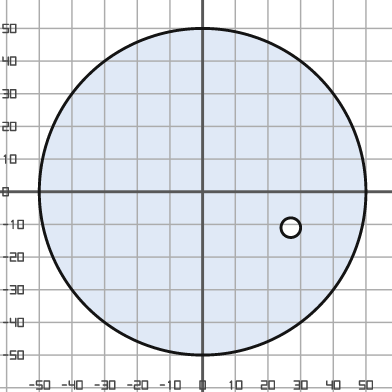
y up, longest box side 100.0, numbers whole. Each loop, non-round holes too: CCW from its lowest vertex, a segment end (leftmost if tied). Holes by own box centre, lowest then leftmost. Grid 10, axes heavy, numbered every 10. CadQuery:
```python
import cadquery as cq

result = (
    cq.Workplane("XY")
    .moveTo(0.0, 0.0)
    .circle(50.0)
    .moveTo(27.0, -11.0)
    .circle(3.0)
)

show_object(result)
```